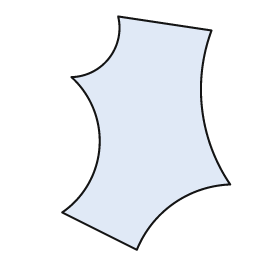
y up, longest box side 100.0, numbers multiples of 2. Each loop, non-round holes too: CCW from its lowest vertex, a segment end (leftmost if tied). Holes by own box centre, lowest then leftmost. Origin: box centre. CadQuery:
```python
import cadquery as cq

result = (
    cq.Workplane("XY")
    .moveTo(-4.0, -50.0)
    .threePointArc((12.0, -30.0), (36.0, -22.0))
    .threePointArc((24.0, 10.0), (28.0, 44.0))
    .lineTo(-12.0, 50.0)
    .threePointArc((-16.0, 32.0), (-32.0, 24.0))
    .threePointArc((-20.0, -6.0), (-36.0, -34.0))
    .close()
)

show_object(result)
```